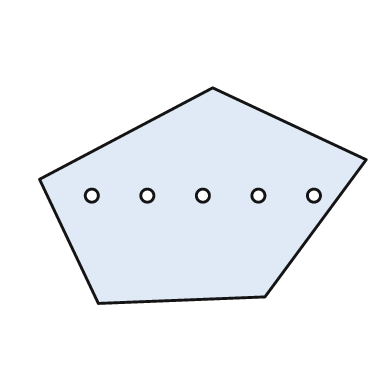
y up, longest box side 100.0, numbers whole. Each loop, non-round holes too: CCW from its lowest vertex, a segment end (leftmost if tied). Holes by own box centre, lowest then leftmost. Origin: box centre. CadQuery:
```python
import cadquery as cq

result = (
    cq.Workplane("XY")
    .moveTo(-32.0, -33.0)
    .lineTo(19.0, -31.0)
    .lineTo(50.0, 11.0)
    .lineTo(3.0, 33.0)
    .lineTo(-50.0, 5.0)
    .close()
    .moveTo(-34.0, 0.0)
    .circle(2.0)
    .moveTo(-17.0, 0.0)
    .circle(2.0)
    .moveTo(0.0, 0.0)
    .circle(2.0)
    .moveTo(17.0, 0.0)
    .circle(2.0)
    .moveTo(34.0, 0.0)
    .circle(2.0)
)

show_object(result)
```